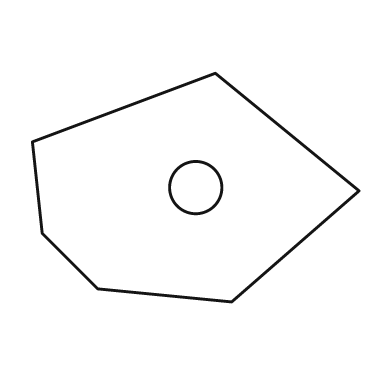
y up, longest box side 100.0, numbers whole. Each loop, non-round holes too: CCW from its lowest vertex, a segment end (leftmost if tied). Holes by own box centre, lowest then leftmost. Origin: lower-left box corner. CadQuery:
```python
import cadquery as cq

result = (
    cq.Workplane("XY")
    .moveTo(61.0, 0.0)
    .lineTo(100.0, 34.0)
    .lineTo(56.0, 70.0)
    .lineTo(0.0, 49.0)
    .lineTo(3.0, 21.0)
    .lineTo(20.0, 4.0)
    .close()
    .moveTo(50.0, 35.0)
    .circle(8.0)
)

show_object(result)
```